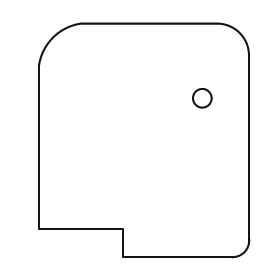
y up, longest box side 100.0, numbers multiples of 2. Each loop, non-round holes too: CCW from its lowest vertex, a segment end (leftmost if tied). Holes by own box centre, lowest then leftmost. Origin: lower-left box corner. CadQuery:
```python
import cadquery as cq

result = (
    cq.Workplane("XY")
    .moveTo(36.0, 0.0)
    .lineTo(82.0, 0.0)
    .threePointArc((88.0, 2.0), (90.0, 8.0))
    .lineTo(90.0, 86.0)
    .threePointArc((86.0, 96.0), (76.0, 100.0))
    .lineTo(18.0, 100.0)
    .threePointArc((6.0, 94.0), (0.0, 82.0))
    .lineTo(0.0, 12.0)
    .lineTo(36.0, 12.0)
    .close()
    .moveTo(70.0, 68.0)
    .circle(4.0)
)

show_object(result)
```